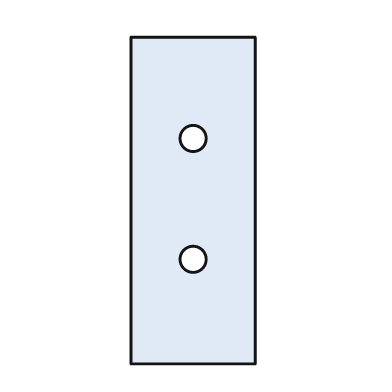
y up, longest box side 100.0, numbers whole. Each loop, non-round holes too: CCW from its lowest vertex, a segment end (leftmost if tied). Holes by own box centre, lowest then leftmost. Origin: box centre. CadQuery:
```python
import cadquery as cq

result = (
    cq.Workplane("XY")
    .moveTo(-19.0, -50.0)
    .lineTo(19.0, -50.0)
    .lineTo(19.0, 50.0)
    .lineTo(-19.0, 50.0)
    .close()
    .moveTo(0.0, -18.0)
    .circle(4.0)
    .moveTo(0.0, 19.0)
    .circle(4.0)
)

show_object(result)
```